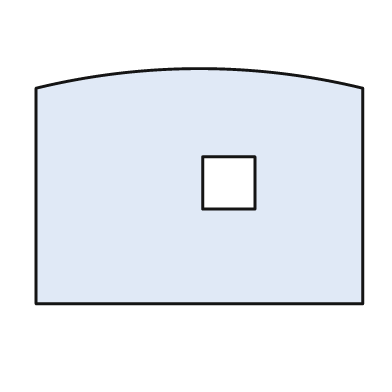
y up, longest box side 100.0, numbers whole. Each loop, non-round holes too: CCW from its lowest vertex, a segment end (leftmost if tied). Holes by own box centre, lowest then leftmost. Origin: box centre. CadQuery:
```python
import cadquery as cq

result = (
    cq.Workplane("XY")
    .moveTo(-50.0, -36.0)
    .lineTo(50.0, -36.0)
    .lineTo(50.0, 30.0)
    .threePointArc((0.0, 36.0), (-50.0, 30.0))
    .close()
    .moveTo(1.0, -7.0)
    .lineTo(17.0, -7.0)
    .lineTo(17.0, 9.0)
    .lineTo(1.0, 9.0)
    .close()
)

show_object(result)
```